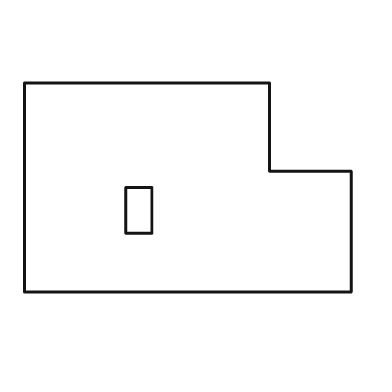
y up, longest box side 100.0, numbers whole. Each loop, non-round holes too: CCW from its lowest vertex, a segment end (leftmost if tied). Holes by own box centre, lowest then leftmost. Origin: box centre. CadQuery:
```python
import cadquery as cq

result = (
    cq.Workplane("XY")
    .moveTo(-50.0, -32.0)
    .lineTo(50.0, -32.0)
    .lineTo(50.0, 5.0)
    .lineTo(25.0, 5.0)
    .lineTo(25.0, 32.0)
    .lineTo(-50.0, 32.0)
    .close()
    .moveTo(-19.0, -14.0)
    .lineTo(-11.0, -14.0)
    .lineTo(-11.0, 0.0)
    .lineTo(-19.0, 0.0)
    .close()
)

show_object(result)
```